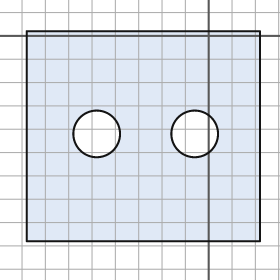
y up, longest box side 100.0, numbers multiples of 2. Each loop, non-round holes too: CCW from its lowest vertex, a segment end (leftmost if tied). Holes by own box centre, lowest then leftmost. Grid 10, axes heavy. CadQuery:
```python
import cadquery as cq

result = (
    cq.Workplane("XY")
    .moveTo(-78.0, -88.0)
    .lineTo(22.0, -88.0)
    .lineTo(22.0, 2.0)
    .lineTo(-78.0, 2.0)
    .close()
    .moveTo(-48.0, -42.0)
    .circle(10.0)
    .moveTo(-6.0, -42.0)
    .circle(10.0)
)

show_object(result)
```